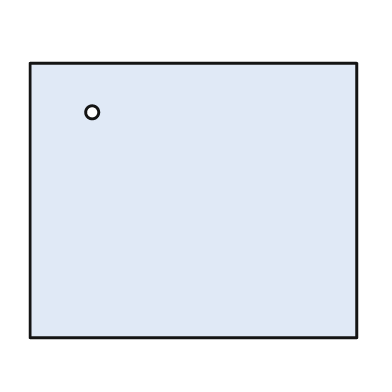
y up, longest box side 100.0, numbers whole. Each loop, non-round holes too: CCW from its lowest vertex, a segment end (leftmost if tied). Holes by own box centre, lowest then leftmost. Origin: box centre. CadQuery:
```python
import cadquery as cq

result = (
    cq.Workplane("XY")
    .moveTo(-50.0, -42.0)
    .lineTo(50.0, -42.0)
    .lineTo(50.0, 42.0)
    .lineTo(-50.0, 42.0)
    .close()
    .moveTo(-31.0, 27.0)
    .circle(2.0)
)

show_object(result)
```